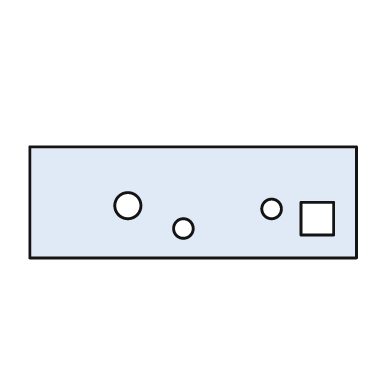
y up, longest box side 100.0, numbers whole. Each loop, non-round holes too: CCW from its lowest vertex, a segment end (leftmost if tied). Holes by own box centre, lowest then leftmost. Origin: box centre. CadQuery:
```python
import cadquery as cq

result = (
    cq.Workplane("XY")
    .moveTo(-50.0, -17.0)
    .lineTo(50.0, -17.0)
    .lineTo(50.0, 17.0)
    .lineTo(-50.0, 17.0)
    .close()
    .moveTo(-3.0, -8.0)
    .circle(3.0)
    .moveTo(33.0, -10.0)
    .lineTo(43.0, -10.0)
    .lineTo(43.0, 0.0)
    .lineTo(33.0, 0.0)
    .close()
    .moveTo(24.0, -2.0)
    .circle(3.0)
    .moveTo(-20.0, -1.0)
    .circle(4.0)
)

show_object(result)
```